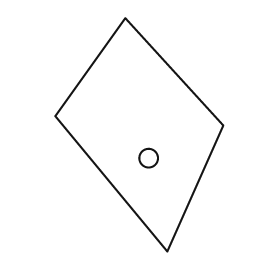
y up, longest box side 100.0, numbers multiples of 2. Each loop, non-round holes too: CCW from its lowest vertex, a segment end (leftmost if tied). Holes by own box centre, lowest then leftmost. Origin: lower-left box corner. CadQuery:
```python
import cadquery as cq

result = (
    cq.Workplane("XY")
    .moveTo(48.0, 0.0)
    .lineTo(72.0, 54.0)
    .lineTo(30.0, 100.0)
    .lineTo(0.0, 58.0)
    .close()
    .moveTo(40.0, 40.0)
    .circle(4.0)
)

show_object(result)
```